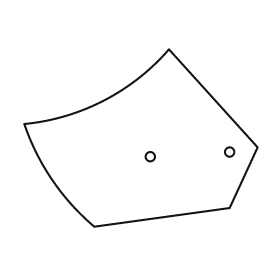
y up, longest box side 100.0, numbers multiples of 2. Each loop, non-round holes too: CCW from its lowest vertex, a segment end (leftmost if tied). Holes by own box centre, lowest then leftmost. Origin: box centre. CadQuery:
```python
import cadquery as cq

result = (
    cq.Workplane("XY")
    .moveTo(-20.0, -38.0)
    .lineTo(38.0, -30.0)
    .lineTo(50.0, -4.0)
    .lineTo(12.0, 38.0)
    .threePointArc((-16.0, 16.0), (-50.0, 6.0))
    .threePointArc((-38.0, -18.0), (-20.0, -38.0))
    .close()
    .moveTo(4.0, -8.0)
    .circle(2.0)
    .moveTo(38.0, -6.0)
    .circle(2.0)
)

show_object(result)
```